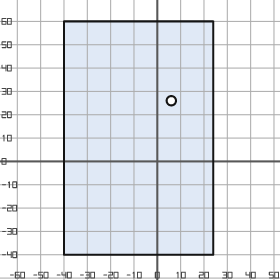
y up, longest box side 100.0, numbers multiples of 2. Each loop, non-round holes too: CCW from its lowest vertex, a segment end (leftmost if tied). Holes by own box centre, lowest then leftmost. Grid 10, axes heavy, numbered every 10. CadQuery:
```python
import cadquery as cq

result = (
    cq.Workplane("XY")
    .moveTo(-40.0, -40.0)
    .lineTo(24.0, -40.0)
    .lineTo(24.0, 60.0)
    .lineTo(-40.0, 60.0)
    .close()
    .moveTo(6.0, 26.0)
    .circle(2.0)
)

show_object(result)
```